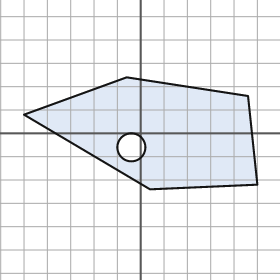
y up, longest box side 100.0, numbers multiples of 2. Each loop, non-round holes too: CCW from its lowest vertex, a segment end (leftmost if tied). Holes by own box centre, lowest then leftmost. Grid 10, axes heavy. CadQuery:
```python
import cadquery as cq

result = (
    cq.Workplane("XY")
    .moveTo(4.0, -24.0)
    .lineTo(50.0, -22.0)
    .lineTo(46.0, 16.0)
    .lineTo(-6.0, 24.0)
    .lineTo(-50.0, 8.0)
    .close()
    .moveTo(-4.0, -6.0)
    .circle(6.0)
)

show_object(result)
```